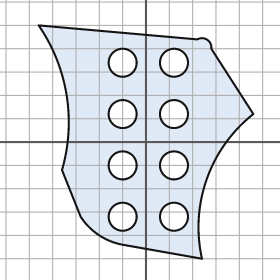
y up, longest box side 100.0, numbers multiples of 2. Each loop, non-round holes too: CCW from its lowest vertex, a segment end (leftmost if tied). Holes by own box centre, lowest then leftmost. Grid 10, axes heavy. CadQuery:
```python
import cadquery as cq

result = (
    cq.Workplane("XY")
    .moveTo(24.0, -50.0)
    .threePointArc((26.0, -16.0), (46.0, 12.0))
    .lineTo(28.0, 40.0)
    .threePointArc((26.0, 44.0), (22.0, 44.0))
    .lineTo(-46.0, 50.0)
    .threePointArc((-34.0, 20.0), (-36.0, -12.0))
    .lineTo(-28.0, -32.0)
    .threePointArc((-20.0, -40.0), (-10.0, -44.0))
    .close()
    .moveTo(-10.0, -32.0)
    .circle(6.0)
    .moveTo(12.0, -32.0)
    .circle(6.0)
    .moveTo(-10.0, -10.0)
    .circle(6.0)
    .moveTo(12.0, -10.0)
    .circle(6.0)
    .moveTo(-10.0, 12.0)
    .circle(6.0)
    .moveTo(12.0, 12.0)
    .circle(6.0)
    .moveTo(-10.0, 34.0)
    .circle(6.0)
    .moveTo(12.0, 34.0)
    .circle(6.0)
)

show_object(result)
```